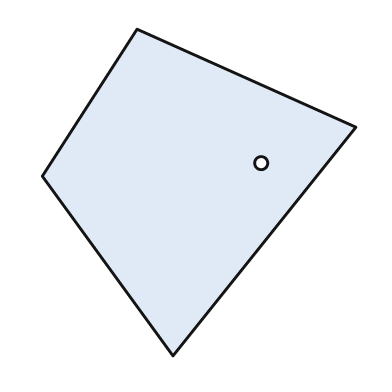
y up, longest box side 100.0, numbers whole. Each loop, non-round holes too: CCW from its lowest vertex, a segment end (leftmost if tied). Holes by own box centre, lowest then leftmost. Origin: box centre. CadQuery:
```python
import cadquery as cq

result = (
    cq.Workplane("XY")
    .moveTo(-8.0, -50.0)
    .lineTo(48.0, 20.0)
    .lineTo(-19.0, 50.0)
    .lineTo(-48.0, 5.0)
    .close()
    .moveTo(19.0, 9.0)
    .circle(2.0)
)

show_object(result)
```